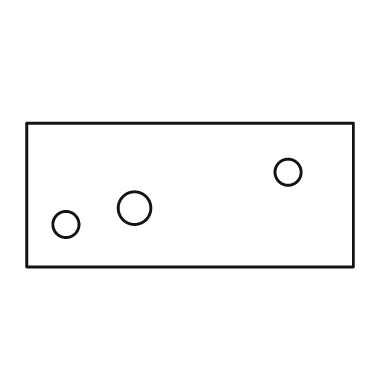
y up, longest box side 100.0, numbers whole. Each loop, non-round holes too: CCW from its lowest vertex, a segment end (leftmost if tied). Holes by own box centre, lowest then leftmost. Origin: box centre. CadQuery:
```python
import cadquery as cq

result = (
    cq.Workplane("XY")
    .moveTo(-50.0, -22.0)
    .lineTo(50.0, -22.0)
    .lineTo(50.0, 22.0)
    .lineTo(-50.0, 22.0)
    .close()
    .moveTo(-38.0, -9.0)
    .circle(4.0)
    .moveTo(-17.0, -4.0)
    .circle(5.0)
    .moveTo(30.0, 7.0)
    .circle(4.0)
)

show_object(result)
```